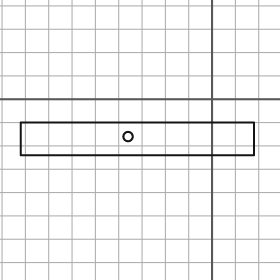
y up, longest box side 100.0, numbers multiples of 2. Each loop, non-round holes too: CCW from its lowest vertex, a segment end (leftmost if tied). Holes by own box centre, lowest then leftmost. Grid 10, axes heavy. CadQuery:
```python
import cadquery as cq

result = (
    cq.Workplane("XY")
    .moveTo(-82.0, -24.0)
    .lineTo(18.0, -24.0)
    .lineTo(18.0, -10.0)
    .lineTo(-82.0, -10.0)
    .close()
    .moveTo(-36.0, -16.0)
    .circle(2.0)
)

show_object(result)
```